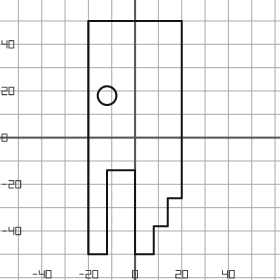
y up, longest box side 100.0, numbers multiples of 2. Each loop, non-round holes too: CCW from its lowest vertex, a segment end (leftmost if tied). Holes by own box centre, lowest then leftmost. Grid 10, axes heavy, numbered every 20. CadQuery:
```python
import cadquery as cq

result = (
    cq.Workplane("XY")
    .moveTo(-20.0, -50.0)
    .lineTo(-12.0, -50.0)
    .lineTo(-12.0, -14.0)
    .lineTo(0.0, -14.0)
    .lineTo(0.0, -50.0)
    .lineTo(8.0, -50.0)
    .lineTo(8.0, -38.0)
    .lineTo(14.0, -38.0)
    .lineTo(14.0, -26.0)
    .lineTo(20.0, -26.0)
    .lineTo(20.0, 50.0)
    .lineTo(-20.0, 50.0)
    .close()
    .moveTo(-12.0, 18.0)
    .circle(4.0)
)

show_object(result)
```